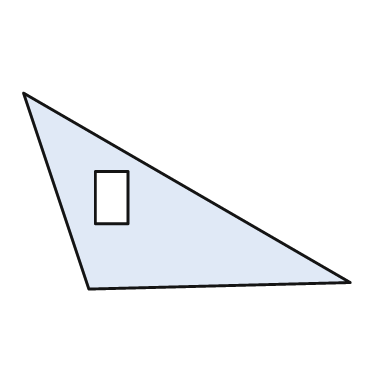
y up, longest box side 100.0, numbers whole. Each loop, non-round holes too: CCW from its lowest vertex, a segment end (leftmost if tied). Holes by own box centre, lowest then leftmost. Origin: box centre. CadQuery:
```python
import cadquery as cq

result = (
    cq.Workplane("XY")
    .moveTo(-30.0, -30.0)
    .lineTo(50.0, -28.0)
    .lineTo(-50.0, 30.0)
    .close()
    .moveTo(-28.0, -10.0)
    .lineTo(-18.0, -10.0)
    .lineTo(-18.0, 6.0)
    .lineTo(-28.0, 6.0)
    .close()
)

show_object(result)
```